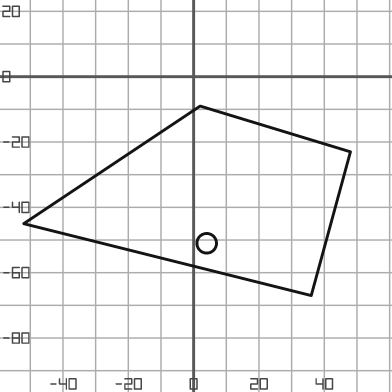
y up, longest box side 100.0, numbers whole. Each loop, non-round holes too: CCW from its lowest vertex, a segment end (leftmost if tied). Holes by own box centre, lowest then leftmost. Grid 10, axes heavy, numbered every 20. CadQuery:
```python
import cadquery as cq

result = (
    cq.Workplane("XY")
    .moveTo(36.0, -67.0)
    .lineTo(48.0, -23.0)
    .lineTo(2.0, -9.0)
    .lineTo(-52.0, -45.0)
    .close()
    .moveTo(4.0, -51.0)
    .circle(3.0)
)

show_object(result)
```